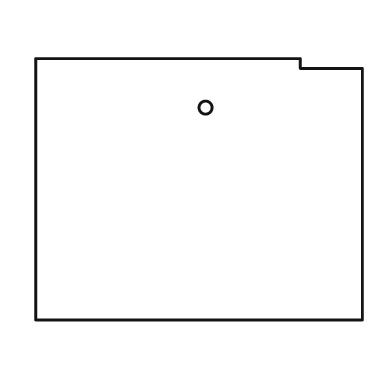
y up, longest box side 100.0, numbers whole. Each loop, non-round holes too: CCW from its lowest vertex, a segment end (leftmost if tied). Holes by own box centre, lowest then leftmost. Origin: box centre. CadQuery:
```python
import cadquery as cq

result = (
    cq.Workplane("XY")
    .moveTo(-50.0, -40.0)
    .lineTo(50.0, -40.0)
    .lineTo(50.0, 37.0)
    .lineTo(31.0, 37.0)
    .lineTo(31.0, 40.0)
    .lineTo(-50.0, 40.0)
    .close()
    .moveTo(2.0, 25.0)
    .circle(2.0)
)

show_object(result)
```